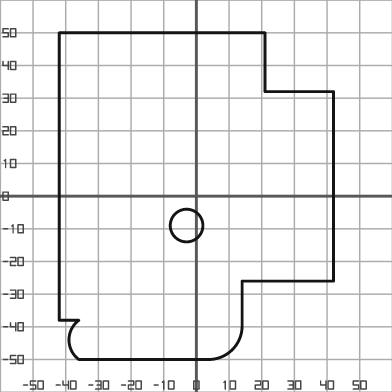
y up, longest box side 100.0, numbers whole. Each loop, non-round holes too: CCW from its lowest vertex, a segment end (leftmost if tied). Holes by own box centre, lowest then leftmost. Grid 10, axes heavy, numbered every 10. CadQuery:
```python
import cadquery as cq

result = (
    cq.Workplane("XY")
    .moveTo(-36.0, -50.0)
    .lineTo(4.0, -50.0)
    .threePointArc((11.0, -47.0), (14.0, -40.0))
    .lineTo(14.0, -26.0)
    .lineTo(42.0, -26.0)
    .lineTo(42.0, 32.0)
    .lineTo(21.0, 32.0)
    .lineTo(21.0, 50.0)
    .lineTo(-42.0, 50.0)
    .lineTo(-42.0, -38.0)
    .lineTo(-36.0, -38.0)
    .threePointArc((-39.0, -44.0), (-36.0, -50.0))
    .close()
    .moveTo(-3.0, -9.0)
    .circle(5.0)
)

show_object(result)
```